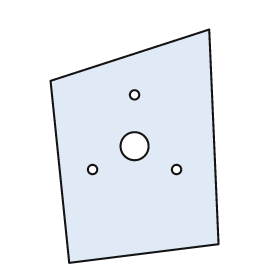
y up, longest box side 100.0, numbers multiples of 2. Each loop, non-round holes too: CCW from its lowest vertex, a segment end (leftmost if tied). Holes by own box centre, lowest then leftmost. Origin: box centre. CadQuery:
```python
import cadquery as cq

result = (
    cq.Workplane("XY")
    .moveTo(-28.0, -50.0)
    .lineTo(36.0, -42.0)
    .lineTo(32.0, 50.0)
    .lineTo(-36.0, 28.0)
    .close()
    .moveTo(-18.0, -10.0)
    .circle(2.0)
    .moveTo(18.0, -10.0)
    .circle(2.0)
    .moveTo(0.0, 0.0)
    .circle(6.0)
    .moveTo(0.0, 22.0)
    .circle(2.0)
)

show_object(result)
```